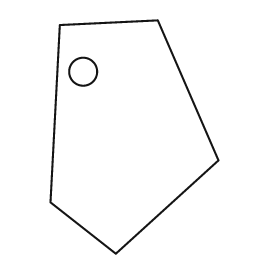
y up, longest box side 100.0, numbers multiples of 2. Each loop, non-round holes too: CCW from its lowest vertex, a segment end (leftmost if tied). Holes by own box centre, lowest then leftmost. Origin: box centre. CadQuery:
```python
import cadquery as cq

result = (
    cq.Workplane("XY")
    .moveTo(-8.0, -50.0)
    .lineTo(36.0, -10.0)
    .lineTo(10.0, 50.0)
    .lineTo(-32.0, 48.0)
    .lineTo(-36.0, -28.0)
    .close()
    .moveTo(-22.0, 28.0)
    .circle(6.0)
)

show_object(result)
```